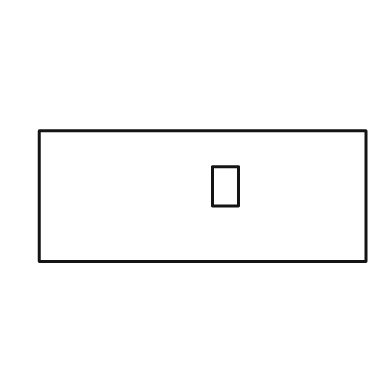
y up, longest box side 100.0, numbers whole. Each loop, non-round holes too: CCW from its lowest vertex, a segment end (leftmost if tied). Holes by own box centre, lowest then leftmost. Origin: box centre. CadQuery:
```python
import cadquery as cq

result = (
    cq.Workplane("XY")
    .moveTo(-50.0, -20.0)
    .lineTo(50.0, -20.0)
    .lineTo(50.0, 20.0)
    .lineTo(-50.0, 20.0)
    .close()
    .moveTo(3.0, -3.0)
    .lineTo(11.0, -3.0)
    .lineTo(11.0, 9.0)
    .lineTo(3.0, 9.0)
    .close()
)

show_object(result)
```